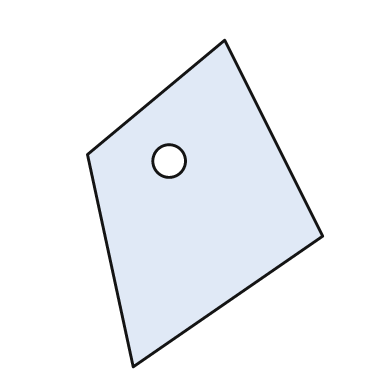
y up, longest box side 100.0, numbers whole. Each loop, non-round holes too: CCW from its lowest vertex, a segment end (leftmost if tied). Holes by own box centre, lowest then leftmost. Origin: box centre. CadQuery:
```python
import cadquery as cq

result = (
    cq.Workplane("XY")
    .moveTo(-22.0, -50.0)
    .lineTo(36.0, -10.0)
    .lineTo(6.0, 50.0)
    .lineTo(-36.0, 15.0)
    .close()
    .moveTo(-11.0, 13.0)
    .circle(5.0)
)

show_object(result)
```